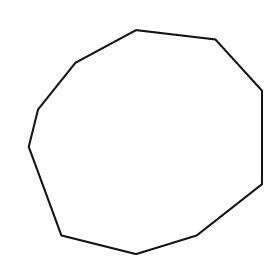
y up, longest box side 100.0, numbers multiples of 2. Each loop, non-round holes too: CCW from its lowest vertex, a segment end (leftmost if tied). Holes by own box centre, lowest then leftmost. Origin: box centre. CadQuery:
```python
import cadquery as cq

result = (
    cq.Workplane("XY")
    .moveTo(-4.0, -48.0)
    .lineTo(22.0, -40.0)
    .lineTo(50.0, -18.0)
    .lineTo(50.0, 22.0)
    .lineTo(30.0, 44.0)
    .lineTo(-4.0, 48.0)
    .lineTo(-30.0, 34.0)
    .lineTo(-46.0, 14.0)
    .lineTo(-50.0, -2.0)
    .lineTo(-36.0, -40.0)
    .close()
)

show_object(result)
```